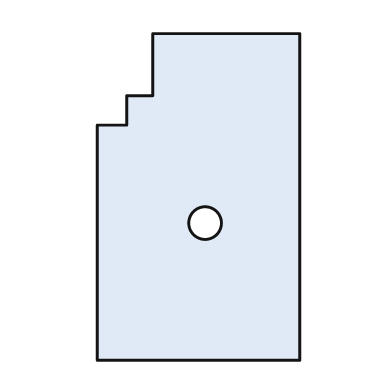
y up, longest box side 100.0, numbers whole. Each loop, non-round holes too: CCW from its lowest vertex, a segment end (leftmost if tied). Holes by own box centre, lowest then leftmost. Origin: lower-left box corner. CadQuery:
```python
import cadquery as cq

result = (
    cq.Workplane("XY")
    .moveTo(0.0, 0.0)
    .lineTo(62.0, 0.0)
    .lineTo(62.0, 100.0)
    .lineTo(17.0, 100.0)
    .lineTo(17.0, 81.0)
    .lineTo(9.0, 81.0)
    .lineTo(9.0, 72.0)
    .lineTo(0.0, 72.0)
    .close()
    .moveTo(33.0, 42.0)
    .circle(5.0)
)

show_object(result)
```